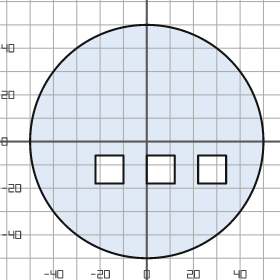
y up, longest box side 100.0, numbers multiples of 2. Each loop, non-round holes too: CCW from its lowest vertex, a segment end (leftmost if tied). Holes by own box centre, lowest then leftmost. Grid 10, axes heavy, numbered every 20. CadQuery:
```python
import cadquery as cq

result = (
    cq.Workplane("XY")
    .moveTo(0.0, 0.0)
    .circle(50.0)
    .moveTo(-22.0, -18.0)
    .lineTo(-10.0, -18.0)
    .lineTo(-10.0, -6.0)
    .lineTo(-22.0, -6.0)
    .close()
    .moveTo(0.0, -18.0)
    .lineTo(12.0, -18.0)
    .lineTo(12.0, -6.0)
    .lineTo(0.0, -6.0)
    .close()
    .moveTo(22.0, -18.0)
    .lineTo(34.0, -18.0)
    .lineTo(34.0, -6.0)
    .lineTo(22.0, -6.0)
    .close()
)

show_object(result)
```